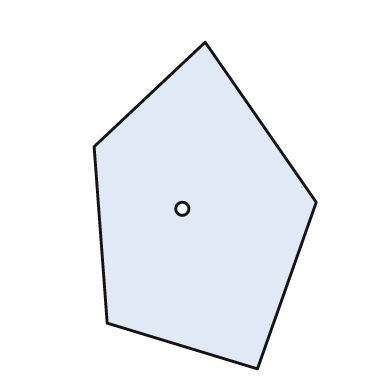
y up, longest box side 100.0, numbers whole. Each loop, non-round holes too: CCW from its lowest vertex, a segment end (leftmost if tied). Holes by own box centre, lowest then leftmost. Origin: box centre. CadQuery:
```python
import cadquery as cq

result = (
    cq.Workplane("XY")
    .moveTo(16.0, -50.0)
    .lineTo(34.0, 1.0)
    .lineTo(0.0, 50.0)
    .lineTo(-34.0, 18.0)
    .lineTo(-30.0, -36.0)
    .close()
    .moveTo(-7.0, -1.0)
    .circle(2.0)
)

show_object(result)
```